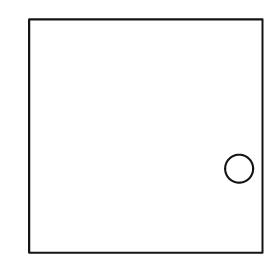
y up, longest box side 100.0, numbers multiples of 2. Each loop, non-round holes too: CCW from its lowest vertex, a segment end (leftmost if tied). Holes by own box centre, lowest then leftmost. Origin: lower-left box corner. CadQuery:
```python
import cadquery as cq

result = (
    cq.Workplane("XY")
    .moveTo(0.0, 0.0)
    .lineTo(100.0, 0.0)
    .lineTo(100.0, 100.0)
    .lineTo(0.0, 100.0)
    .close()
    .moveTo(90.0, 36.0)
    .circle(6.0)
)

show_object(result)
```